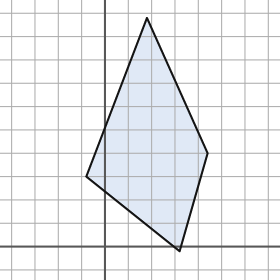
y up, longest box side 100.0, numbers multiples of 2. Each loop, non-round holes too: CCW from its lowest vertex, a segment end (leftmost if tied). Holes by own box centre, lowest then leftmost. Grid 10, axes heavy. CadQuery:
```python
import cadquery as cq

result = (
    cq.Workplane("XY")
    .moveTo(32.0, -2.0)
    .lineTo(44.0, 40.0)
    .lineTo(18.0, 98.0)
    .lineTo(-8.0, 30.0)
    .close()
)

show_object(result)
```